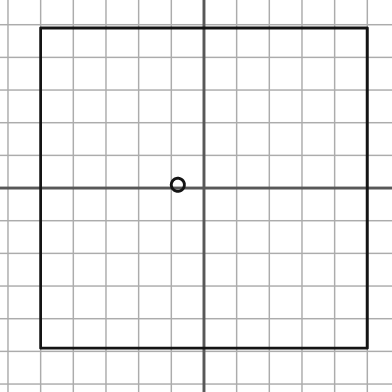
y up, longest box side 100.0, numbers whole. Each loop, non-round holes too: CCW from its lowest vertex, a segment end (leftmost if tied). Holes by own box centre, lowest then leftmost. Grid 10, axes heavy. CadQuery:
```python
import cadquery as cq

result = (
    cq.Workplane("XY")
    .moveTo(-50.0, -49.0)
    .lineTo(50.0, -49.0)
    .lineTo(50.0, 49.0)
    .lineTo(-50.0, 49.0)
    .close()
    .moveTo(-8.0, 1.0)
    .circle(2.0)
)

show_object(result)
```